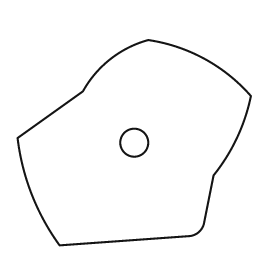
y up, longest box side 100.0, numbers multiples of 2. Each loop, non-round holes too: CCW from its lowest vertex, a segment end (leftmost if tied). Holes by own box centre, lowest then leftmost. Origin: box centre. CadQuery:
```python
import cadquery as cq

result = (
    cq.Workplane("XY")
    .moveTo(-32.0, -44.0)
    .lineTo(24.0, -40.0)
    .threePointArc((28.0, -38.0), (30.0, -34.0))
    .lineTo(34.0, -14.0)
    .threePointArc((44.0, 2.0), (50.0, 20.0))
    .threePointArc((30.0, 36.0), (6.0, 44.0))
    .threePointArc((-10.0, 36.0), (-22.0, 22.0))
    .lineTo(-50.0, 2.0)
    .threePointArc((-44.0, -22.0), (-32.0, -44.0))
    .close()
    .moveTo(0.0, 0.0)
    .circle(6.0)
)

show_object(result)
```